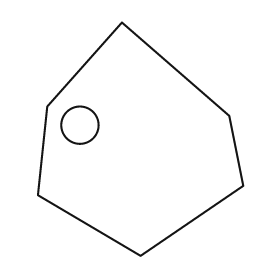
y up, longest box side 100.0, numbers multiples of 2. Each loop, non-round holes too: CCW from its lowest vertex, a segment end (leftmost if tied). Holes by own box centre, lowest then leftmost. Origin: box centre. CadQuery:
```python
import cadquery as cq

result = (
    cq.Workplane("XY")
    .moveTo(0.0, -50.0)
    .lineTo(44.0, -20.0)
    .lineTo(38.0, 10.0)
    .lineTo(-8.0, 50.0)
    .lineTo(-40.0, 14.0)
    .lineTo(-44.0, -24.0)
    .close()
    .moveTo(-26.0, 6.0)
    .circle(8.0)
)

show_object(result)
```